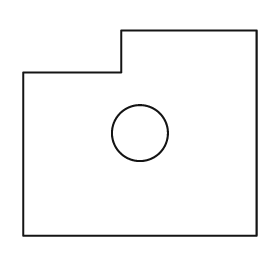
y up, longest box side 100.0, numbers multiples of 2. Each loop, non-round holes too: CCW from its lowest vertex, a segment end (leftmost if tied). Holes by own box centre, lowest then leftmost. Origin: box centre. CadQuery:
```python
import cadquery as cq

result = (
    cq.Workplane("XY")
    .moveTo(-50.0, -44.0)
    .lineTo(50.0, -44.0)
    .lineTo(50.0, 44.0)
    .lineTo(-8.0, 44.0)
    .lineTo(-8.0, 26.0)
    .lineTo(-50.0, 26.0)
    .close()
    .moveTo(0.0, 0.0)
    .circle(12.0)
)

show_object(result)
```